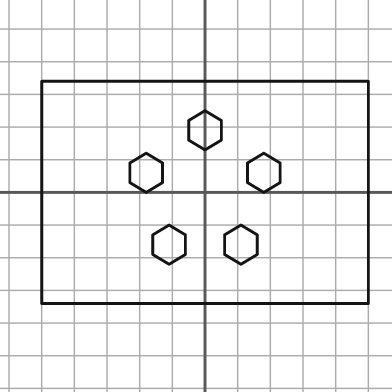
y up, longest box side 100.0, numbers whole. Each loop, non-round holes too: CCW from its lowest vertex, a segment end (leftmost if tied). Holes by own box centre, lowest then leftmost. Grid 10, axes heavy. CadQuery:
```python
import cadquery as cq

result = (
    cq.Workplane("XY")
    .moveTo(-50.0, -34.0)
    .lineTo(50.0, -34.0)
    .lineTo(50.0, 34.0)
    .lineTo(-50.0, 34.0)
    .close()
    .moveTo(-11.0, -22.0)
    .lineTo(-6.0, -19.0)
    .lineTo(-6.0, -13.0)
    .lineTo(-11.0, -10.0)
    .lineTo(-16.0, -13.0)
    .lineTo(-16.0, -19.0)
    .close()
    .moveTo(11.0, -22.0)
    .lineTo(16.0, -19.0)
    .lineTo(16.0, -13.0)
    .lineTo(11.0, -10.0)
    .lineTo(6.0, -13.0)
    .lineTo(6.0, -19.0)
    .close()
    .moveTo(-18.0, 0.0)
    .lineTo(-13.0, 3.0)
    .lineTo(-13.0, 9.0)
    .lineTo(-18.0, 12.0)
    .lineTo(-23.0, 9.0)
    .lineTo(-23.0, 3.0)
    .close()
    .moveTo(18.0, 0.0)
    .lineTo(23.0, 3.0)
    .lineTo(23.0, 9.0)
    .lineTo(18.0, 12.0)
    .lineTo(13.0, 9.0)
    .lineTo(13.0, 3.0)
    .close()
    .moveTo(0.0, 13.0)
    .lineTo(5.0, 16.0)
    .lineTo(5.0, 22.0)
    .lineTo(0.0, 25.0)
    .lineTo(-5.0, 22.0)
    .lineTo(-5.0, 16.0)
    .close()
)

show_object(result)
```